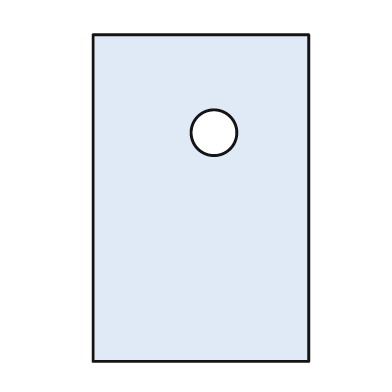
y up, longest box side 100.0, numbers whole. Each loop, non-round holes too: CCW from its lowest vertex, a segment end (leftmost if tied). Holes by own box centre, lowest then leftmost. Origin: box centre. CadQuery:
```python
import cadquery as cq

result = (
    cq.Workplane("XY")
    .moveTo(-33.0, -50.0)
    .lineTo(33.0, -50.0)
    .lineTo(33.0, 50.0)
    .lineTo(-33.0, 50.0)
    .close()
    .moveTo(4.0, 20.0)
    .circle(7.0)
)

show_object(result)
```